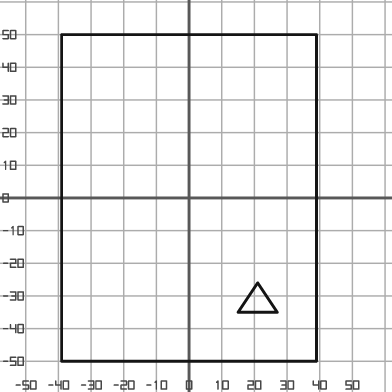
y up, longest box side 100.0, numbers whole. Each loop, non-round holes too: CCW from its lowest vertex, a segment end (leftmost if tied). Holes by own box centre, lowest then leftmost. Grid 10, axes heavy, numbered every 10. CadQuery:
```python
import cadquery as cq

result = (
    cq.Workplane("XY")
    .moveTo(-39.0, -50.0)
    .lineTo(39.0, -50.0)
    .lineTo(39.0, 50.0)
    .lineTo(-39.0, 50.0)
    .close()
    .moveTo(15.0, -35.0)
    .lineTo(27.0, -35.0)
    .lineTo(21.0, -26.0)
    .close()
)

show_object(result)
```